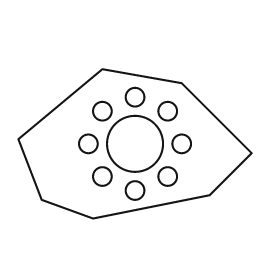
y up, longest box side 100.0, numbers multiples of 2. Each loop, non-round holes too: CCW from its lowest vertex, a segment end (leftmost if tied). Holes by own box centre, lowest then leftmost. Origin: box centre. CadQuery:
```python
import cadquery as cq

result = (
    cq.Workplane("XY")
    .moveTo(-18.0, -32.0)
    .lineTo(32.0, -22.0)
    .lineTo(50.0, -4.0)
    .lineTo(20.0, 26.0)
    .lineTo(-14.0, 32.0)
    .lineTo(-50.0, 2.0)
    .lineTo(-40.0, -24.0)
    .close()
    .moveTo(0.0, -20.0)
    .circle(4.0)
    .moveTo(-14.0, -14.0)
    .circle(4.0)
    .moveTo(14.0, -14.0)
    .circle(4.0)
    .moveTo(-20.0, 0.0)
    .circle(4.0)
    .moveTo(0.0, 0.0)
    .circle(12.0)
    .moveTo(20.0, 0.0)
    .circle(4.0)
    .moveTo(-14.0, 14.0)
    .circle(4.0)
    .moveTo(14.0, 14.0)
    .circle(4.0)
    .moveTo(0.0, 20.0)
    .circle(4.0)
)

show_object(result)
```